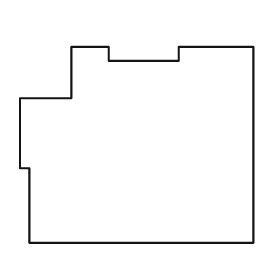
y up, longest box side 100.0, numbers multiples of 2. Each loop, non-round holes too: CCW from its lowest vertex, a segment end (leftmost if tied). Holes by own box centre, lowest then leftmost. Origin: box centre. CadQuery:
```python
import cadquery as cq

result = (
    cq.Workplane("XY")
    .moveTo(-46.0, -42.0)
    .lineTo(50.0, -42.0)
    .lineTo(50.0, 42.0)
    .lineTo(18.0, 42.0)
    .lineTo(18.0, 36.0)
    .lineTo(-12.0, 36.0)
    .lineTo(-12.0, 42.0)
    .lineTo(-28.0, 42.0)
    .lineTo(-28.0, 20.0)
    .lineTo(-50.0, 20.0)
    .lineTo(-50.0, -10.0)
    .lineTo(-46.0, -10.0)
    .close()
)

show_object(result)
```